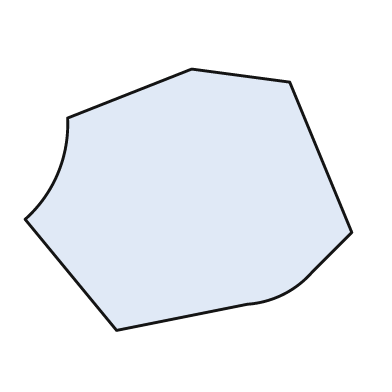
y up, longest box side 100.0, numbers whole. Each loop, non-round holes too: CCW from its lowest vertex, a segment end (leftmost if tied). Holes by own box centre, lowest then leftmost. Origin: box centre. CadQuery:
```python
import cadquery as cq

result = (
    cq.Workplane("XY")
    .moveTo(-22.0, -40.0)
    .lineTo(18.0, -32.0)
    .threePointArc((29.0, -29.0), (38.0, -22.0))
    .lineTo(50.0, -10.0)
    .lineTo(31.0, 36.0)
    .lineTo(1.0, 40.0)
    .lineTo(-37.0, 25.0)
    .threePointArc((-40.0, 8.0), (-50.0, -6.0))
    .close()
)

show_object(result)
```